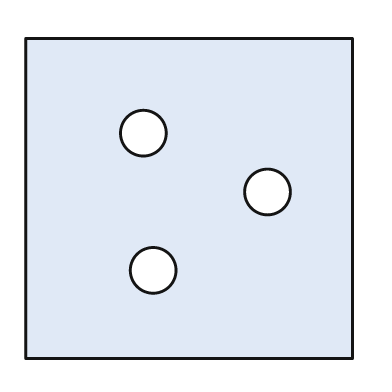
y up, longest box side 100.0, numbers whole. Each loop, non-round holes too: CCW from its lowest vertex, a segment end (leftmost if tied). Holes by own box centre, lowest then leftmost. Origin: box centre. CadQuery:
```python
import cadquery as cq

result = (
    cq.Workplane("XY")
    .moveTo(-50.0, -49.0)
    .lineTo(50.0, -49.0)
    .lineTo(50.0, 49.0)
    .lineTo(-50.0, 49.0)
    .close()
    .moveTo(-11.0, -22.0)
    .circle(7.0)
    .moveTo(24.0, 2.0)
    .circle(7.0)
    .moveTo(-14.0, 20.0)
    .circle(7.0)
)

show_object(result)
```